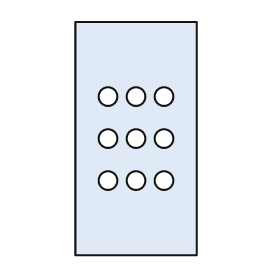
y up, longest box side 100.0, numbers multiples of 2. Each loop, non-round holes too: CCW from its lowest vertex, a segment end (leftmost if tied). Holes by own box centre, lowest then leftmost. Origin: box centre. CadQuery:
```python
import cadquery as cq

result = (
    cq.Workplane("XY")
    .moveTo(-26.0, -50.0)
    .lineTo(26.0, -50.0)
    .lineTo(26.0, 50.0)
    .lineTo(-26.0, 50.0)
    .close()
    .moveTo(-12.0, -18.0)
    .circle(4.0)
    .moveTo(0.0, -18.0)
    .circle(4.0)
    .moveTo(12.0, -18.0)
    .circle(4.0)
    .moveTo(-12.0, 0.0)
    .circle(4.0)
    .moveTo(0.0, 0.0)
    .circle(4.0)
    .moveTo(12.0, 0.0)
    .circle(4.0)
    .moveTo(-12.0, 18.0)
    .circle(4.0)
    .moveTo(0.0, 18.0)
    .circle(4.0)
    .moveTo(12.0, 18.0)
    .circle(4.0)
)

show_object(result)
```